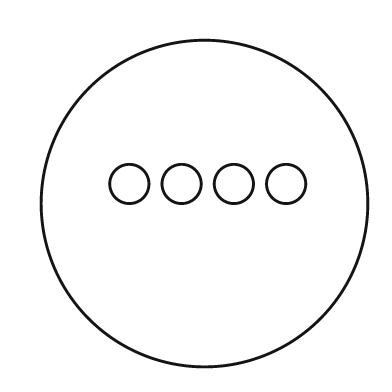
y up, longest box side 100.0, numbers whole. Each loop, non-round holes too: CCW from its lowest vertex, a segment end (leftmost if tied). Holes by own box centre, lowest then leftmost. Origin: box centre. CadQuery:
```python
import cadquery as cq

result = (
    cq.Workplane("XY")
    .moveTo(0.0, 0.0)
    .circle(50.0)
    .moveTo(-23.0, 6.0)
    .circle(6.0)
    .moveTo(-7.0, 6.0)
    .circle(6.0)
    .moveTo(9.0, 6.0)
    .circle(6.0)
    .moveTo(25.0, 6.0)
    .circle(6.0)
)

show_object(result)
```